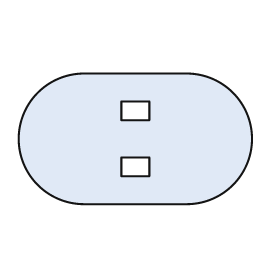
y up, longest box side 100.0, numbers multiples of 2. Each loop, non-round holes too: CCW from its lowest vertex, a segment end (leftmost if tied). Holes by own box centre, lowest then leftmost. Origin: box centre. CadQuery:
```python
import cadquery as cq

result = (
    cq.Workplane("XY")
    .moveTo(-22.0, -28.0)
    .lineTo(22.0, -28.0)
    .threePointArc((50.0, 0.0), (22.0, 28.0))
    .lineTo(-22.0, 28.0)
    .threePointArc((-50.0, 0.0), (-22.0, -28.0))
    .close()
    .moveTo(-6.0, -16.0)
    .lineTo(6.0, -16.0)
    .lineTo(6.0, -8.0)
    .lineTo(-6.0, -8.0)
    .close()
    .moveTo(-6.0, 8.0)
    .lineTo(6.0, 8.0)
    .lineTo(6.0, 16.0)
    .lineTo(-6.0, 16.0)
    .close()
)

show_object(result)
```